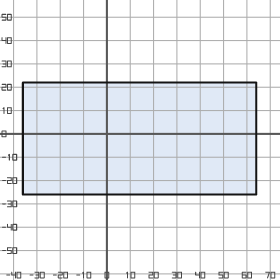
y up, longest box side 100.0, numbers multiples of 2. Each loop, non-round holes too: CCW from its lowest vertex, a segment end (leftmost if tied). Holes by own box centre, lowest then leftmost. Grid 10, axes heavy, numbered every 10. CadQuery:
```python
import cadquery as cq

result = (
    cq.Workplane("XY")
    .moveTo(-36.0, -26.0)
    .lineTo(64.0, -26.0)
    .lineTo(64.0, 22.0)
    .lineTo(-36.0, 22.0)
    .close()
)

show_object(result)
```